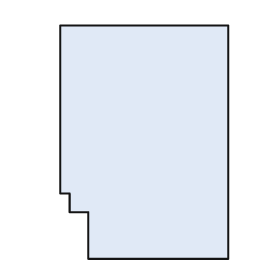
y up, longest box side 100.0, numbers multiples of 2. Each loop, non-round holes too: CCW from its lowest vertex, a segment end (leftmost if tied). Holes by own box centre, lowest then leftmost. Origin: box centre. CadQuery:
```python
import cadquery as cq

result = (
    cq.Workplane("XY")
    .moveTo(-24.0, -50.0)
    .lineTo(36.0, -50.0)
    .lineTo(36.0, 50.0)
    .lineTo(-36.0, 50.0)
    .lineTo(-36.0, -22.0)
    .lineTo(-32.0, -22.0)
    .lineTo(-32.0, -30.0)
    .lineTo(-24.0, -30.0)
    .close()
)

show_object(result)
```